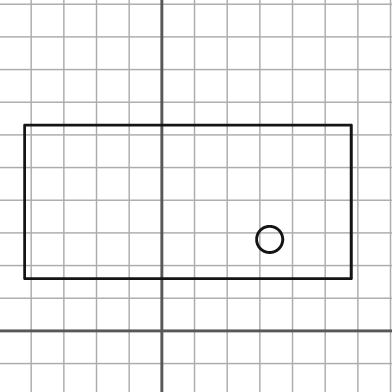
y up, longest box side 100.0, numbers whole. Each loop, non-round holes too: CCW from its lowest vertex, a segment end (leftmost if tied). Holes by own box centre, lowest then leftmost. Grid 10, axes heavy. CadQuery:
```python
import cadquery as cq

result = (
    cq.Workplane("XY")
    .moveTo(-42.0, 16.0)
    .lineTo(58.0, 16.0)
    .lineTo(58.0, 63.0)
    .lineTo(-42.0, 63.0)
    .close()
    .moveTo(33.0, 28.0)
    .circle(4.0)
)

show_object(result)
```